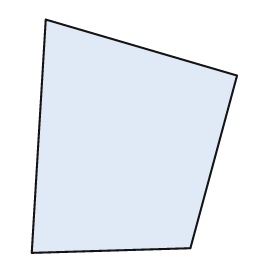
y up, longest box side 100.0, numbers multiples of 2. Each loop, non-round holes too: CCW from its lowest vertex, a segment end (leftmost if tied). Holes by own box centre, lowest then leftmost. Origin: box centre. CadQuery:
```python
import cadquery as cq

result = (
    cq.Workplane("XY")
    .moveTo(-44.0, -50.0)
    .lineTo(24.0, -48.0)
    .lineTo(44.0, 26.0)
    .lineTo(-38.0, 50.0)
    .close()
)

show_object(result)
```